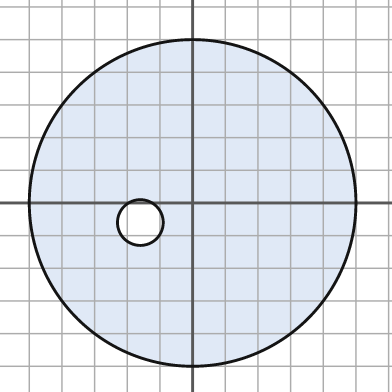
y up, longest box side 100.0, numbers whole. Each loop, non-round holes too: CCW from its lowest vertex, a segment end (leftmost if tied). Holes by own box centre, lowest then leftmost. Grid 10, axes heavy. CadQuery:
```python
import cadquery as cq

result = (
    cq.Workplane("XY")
    .moveTo(0.0, 0.0)
    .circle(50.0)
    .moveTo(-16.0, -6.0)
    .circle(7.0)
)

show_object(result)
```